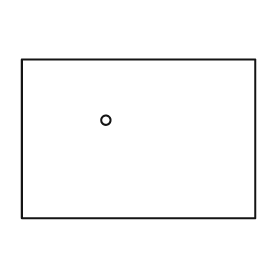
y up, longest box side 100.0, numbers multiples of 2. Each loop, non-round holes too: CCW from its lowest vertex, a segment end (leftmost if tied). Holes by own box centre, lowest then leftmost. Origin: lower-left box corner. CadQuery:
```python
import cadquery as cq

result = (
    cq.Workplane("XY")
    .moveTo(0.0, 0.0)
    .lineTo(100.0, 0.0)
    .lineTo(100.0, 68.0)
    .lineTo(0.0, 68.0)
    .close()
    .moveTo(36.0, 42.0)
    .circle(2.0)
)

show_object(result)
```